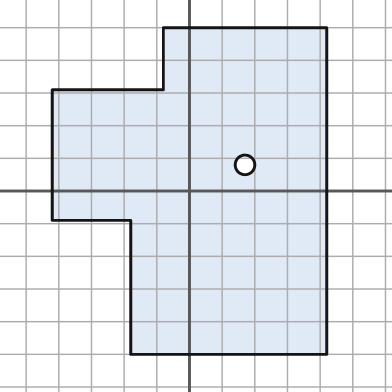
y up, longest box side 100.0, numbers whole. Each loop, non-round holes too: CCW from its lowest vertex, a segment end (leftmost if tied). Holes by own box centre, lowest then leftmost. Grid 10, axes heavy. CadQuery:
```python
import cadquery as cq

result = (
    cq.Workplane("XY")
    .moveTo(-18.0, -50.0)
    .lineTo(42.0, -50.0)
    .lineTo(42.0, 50.0)
    .lineTo(-8.0, 50.0)
    .lineTo(-8.0, 31.0)
    .lineTo(-42.0, 31.0)
    .lineTo(-42.0, -9.0)
    .lineTo(-18.0, -9.0)
    .close()
    .moveTo(17.0, 8.0)
    .circle(3.0)
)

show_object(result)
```